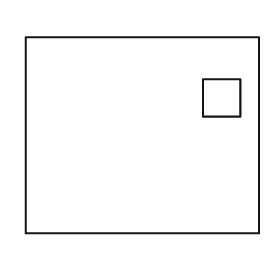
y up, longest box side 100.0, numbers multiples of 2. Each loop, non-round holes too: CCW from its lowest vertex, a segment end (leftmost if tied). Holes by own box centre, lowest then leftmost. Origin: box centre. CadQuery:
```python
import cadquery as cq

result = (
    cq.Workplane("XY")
    .moveTo(-50.0, -42.0)
    .lineTo(50.0, -42.0)
    .lineTo(50.0, 42.0)
    .lineTo(-50.0, 42.0)
    .close()
    .moveTo(26.0, 8.0)
    .lineTo(42.0, 8.0)
    .lineTo(42.0, 24.0)
    .lineTo(26.0, 24.0)
    .close()
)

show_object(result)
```